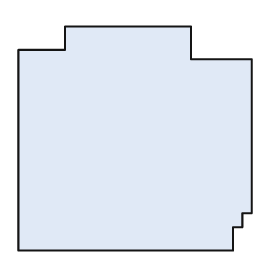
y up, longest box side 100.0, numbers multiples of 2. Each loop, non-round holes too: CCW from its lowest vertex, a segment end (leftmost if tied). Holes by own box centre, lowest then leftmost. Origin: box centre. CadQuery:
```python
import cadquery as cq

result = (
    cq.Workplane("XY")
    .moveTo(-50.0, -48.0)
    .lineTo(42.0, -48.0)
    .lineTo(42.0, -38.0)
    .lineTo(46.0, -38.0)
    .lineTo(46.0, -32.0)
    .lineTo(50.0, -32.0)
    .lineTo(50.0, 34.0)
    .lineTo(24.0, 34.0)
    .lineTo(24.0, 48.0)
    .lineTo(-30.0, 48.0)
    .lineTo(-30.0, 38.0)
    .lineTo(-50.0, 38.0)
    .close()
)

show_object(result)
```